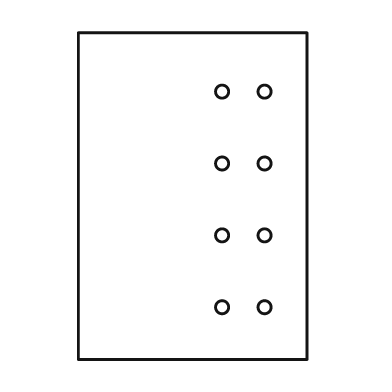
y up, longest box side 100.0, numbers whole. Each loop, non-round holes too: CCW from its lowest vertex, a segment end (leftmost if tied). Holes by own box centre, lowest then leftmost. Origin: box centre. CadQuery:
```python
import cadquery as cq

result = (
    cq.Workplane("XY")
    .moveTo(-35.0, -50.0)
    .lineTo(35.0, -50.0)
    .lineTo(35.0, 50.0)
    .lineTo(-35.0, 50.0)
    .close()
    .moveTo(9.0, -34.0)
    .circle(2.0)
    .moveTo(22.0, -34.0)
    .circle(2.0)
    .moveTo(9.0, -12.0)
    .circle(2.0)
    .moveTo(22.0, -12.0)
    .circle(2.0)
    .moveTo(9.0, 10.0)
    .circle(2.0)
    .moveTo(22.0, 10.0)
    .circle(2.0)
    .moveTo(9.0, 32.0)
    .circle(2.0)
    .moveTo(22.0, 32.0)
    .circle(2.0)
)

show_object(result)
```